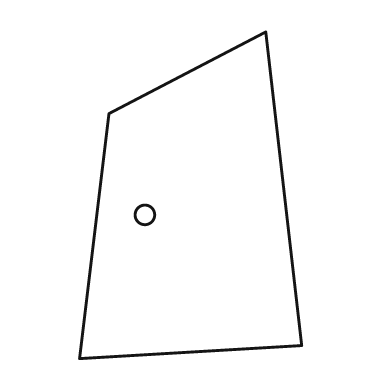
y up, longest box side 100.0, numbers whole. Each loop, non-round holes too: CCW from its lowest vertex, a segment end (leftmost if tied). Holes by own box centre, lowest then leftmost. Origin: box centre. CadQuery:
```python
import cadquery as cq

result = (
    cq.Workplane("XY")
    .moveTo(-34.0, -50.0)
    .lineTo(34.0, -46.0)
    .lineTo(23.0, 50.0)
    .lineTo(-25.0, 25.0)
    .close()
    .moveTo(-14.0, -6.0)
    .circle(3.0)
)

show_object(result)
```